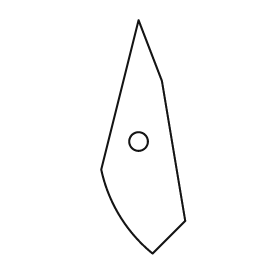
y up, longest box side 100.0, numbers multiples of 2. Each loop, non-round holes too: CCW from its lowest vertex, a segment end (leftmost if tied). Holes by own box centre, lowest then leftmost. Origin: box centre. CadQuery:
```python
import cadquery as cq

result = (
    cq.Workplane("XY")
    .moveTo(4.0, -50.0)
    .lineTo(18.0, -36.0)
    .lineTo(8.0, 24.0)
    .lineTo(-2.0, 50.0)
    .lineTo(-18.0, -14.0)
    .threePointArc((-10.0, -34.0), (4.0, -50.0))
    .close()
    .moveTo(-2.0, -2.0)
    .circle(4.0)
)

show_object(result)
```